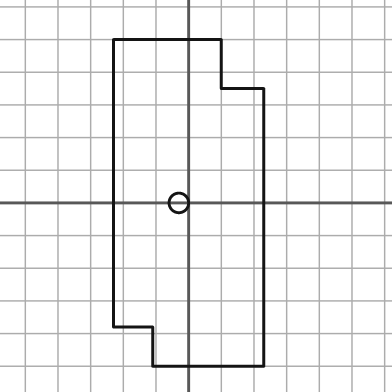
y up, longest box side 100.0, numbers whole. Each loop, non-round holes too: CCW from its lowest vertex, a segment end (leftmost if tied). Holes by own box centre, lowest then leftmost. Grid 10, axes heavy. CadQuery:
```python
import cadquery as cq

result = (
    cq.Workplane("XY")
    .moveTo(-11.0, -50.0)
    .lineTo(23.0, -50.0)
    .lineTo(23.0, 35.0)
    .lineTo(10.0, 35.0)
    .lineTo(10.0, 50.0)
    .lineTo(-23.0, 50.0)
    .lineTo(-23.0, -38.0)
    .lineTo(-11.0, -38.0)
    .close()
    .moveTo(-3.0, 0.0)
    .circle(3.0)
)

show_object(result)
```